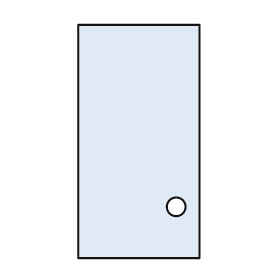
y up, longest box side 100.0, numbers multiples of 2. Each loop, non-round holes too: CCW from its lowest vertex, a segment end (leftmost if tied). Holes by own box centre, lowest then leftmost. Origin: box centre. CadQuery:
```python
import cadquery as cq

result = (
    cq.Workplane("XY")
    .moveTo(-26.0, -50.0)
    .lineTo(26.0, -50.0)
    .lineTo(26.0, 50.0)
    .lineTo(-26.0, 50.0)
    .close()
    .moveTo(16.0, -28.0)
    .circle(4.0)
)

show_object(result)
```